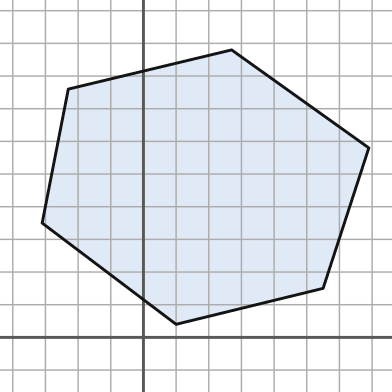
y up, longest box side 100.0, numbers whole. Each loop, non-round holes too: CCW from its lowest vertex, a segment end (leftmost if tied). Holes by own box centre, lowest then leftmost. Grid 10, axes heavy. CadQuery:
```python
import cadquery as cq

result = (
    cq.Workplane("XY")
    .moveTo(10.0, 4.0)
    .lineTo(55.0, 15.0)
    .lineTo(69.0, 58.0)
    .lineTo(27.0, 88.0)
    .lineTo(-23.0, 76.0)
    .lineTo(-31.0, 35.0)
    .close()
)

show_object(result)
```